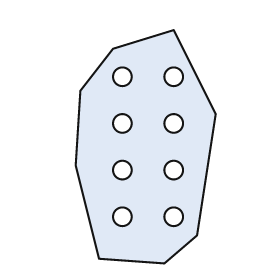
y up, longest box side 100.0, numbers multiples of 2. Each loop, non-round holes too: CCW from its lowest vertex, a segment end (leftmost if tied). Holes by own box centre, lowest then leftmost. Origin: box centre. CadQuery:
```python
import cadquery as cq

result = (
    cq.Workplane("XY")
    .moveTo(8.0, -50.0)
    .lineTo(22.0, -38.0)
    .lineTo(30.0, 14.0)
    .lineTo(12.0, 50.0)
    .lineTo(-14.0, 42.0)
    .lineTo(-28.0, 24.0)
    .lineTo(-30.0, -8.0)
    .lineTo(-20.0, -48.0)
    .close()
    .moveTo(-10.0, -30.0)
    .circle(4.0)
    .moveTo(12.0, -30.0)
    .circle(4.0)
    .moveTo(-10.0, -10.0)
    .circle(4.0)
    .moveTo(12.0, -10.0)
    .circle(4.0)
    .moveTo(-10.0, 10.0)
    .circle(4.0)
    .moveTo(12.0, 10.0)
    .circle(4.0)
    .moveTo(-10.0, 30.0)
    .circle(4.0)
    .moveTo(12.0, 30.0)
    .circle(4.0)
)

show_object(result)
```